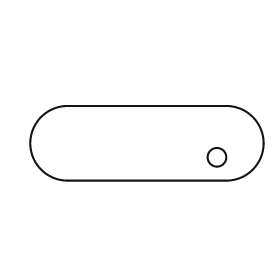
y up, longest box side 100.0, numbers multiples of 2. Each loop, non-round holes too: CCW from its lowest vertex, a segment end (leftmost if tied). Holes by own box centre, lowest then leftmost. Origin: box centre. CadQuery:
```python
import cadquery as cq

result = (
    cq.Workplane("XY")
    .moveTo(-34.0, -16.0)
    .lineTo(34.0, -16.0)
    .threePointArc((50.0, 0.0), (34.0, 16.0))
    .lineTo(-34.0, 16.0)
    .threePointArc((-50.0, 0.0), (-34.0, -16.0))
    .close()
    .moveTo(30.0, -6.0)
    .circle(4.0)
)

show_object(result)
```